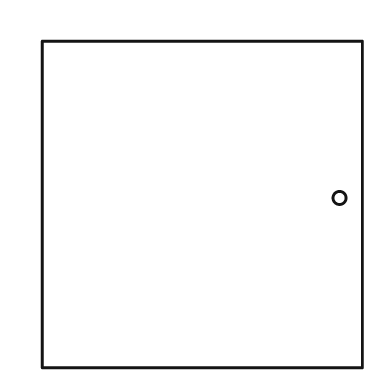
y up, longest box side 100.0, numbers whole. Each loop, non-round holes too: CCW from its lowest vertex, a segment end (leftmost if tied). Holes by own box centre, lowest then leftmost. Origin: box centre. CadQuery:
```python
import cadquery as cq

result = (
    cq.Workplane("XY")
    .moveTo(-49.0, -50.0)
    .lineTo(49.0, -50.0)
    .lineTo(49.0, 50.0)
    .lineTo(-49.0, 50.0)
    .close()
    .moveTo(42.0, 2.0)
    .circle(2.0)
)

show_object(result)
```